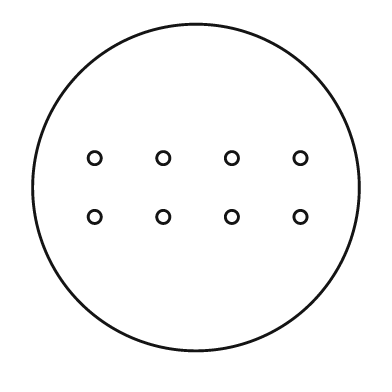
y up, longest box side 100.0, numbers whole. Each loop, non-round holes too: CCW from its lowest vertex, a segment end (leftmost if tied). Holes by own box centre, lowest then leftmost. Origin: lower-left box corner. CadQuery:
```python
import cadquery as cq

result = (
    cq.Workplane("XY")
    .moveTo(50.0, 50.0)
    .circle(50.0)
    .moveTo(19.0, 41.0)
    .circle(2.0)
    .moveTo(40.0, 41.0)
    .circle(2.0)
    .moveTo(61.0, 41.0)
    .circle(2.0)
    .moveTo(82.0, 41.0)
    .circle(2.0)
    .moveTo(19.0, 59.0)
    .circle(2.0)
    .moveTo(40.0, 59.0)
    .circle(2.0)
    .moveTo(61.0, 59.0)
    .circle(2.0)
    .moveTo(82.0, 59.0)
    .circle(2.0)
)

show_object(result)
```